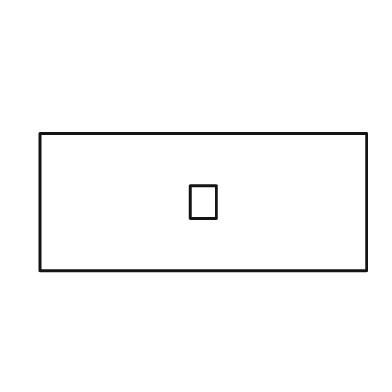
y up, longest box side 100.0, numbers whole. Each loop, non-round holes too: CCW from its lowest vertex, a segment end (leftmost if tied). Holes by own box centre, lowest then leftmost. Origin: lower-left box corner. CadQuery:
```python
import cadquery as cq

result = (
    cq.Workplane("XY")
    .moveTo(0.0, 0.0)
    .lineTo(100.0, 0.0)
    .lineTo(100.0, 42.0)
    .lineTo(0.0, 42.0)
    .close()
    .moveTo(46.0, 16.0)
    .lineTo(54.0, 16.0)
    .lineTo(54.0, 26.0)
    .lineTo(46.0, 26.0)
    .close()
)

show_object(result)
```